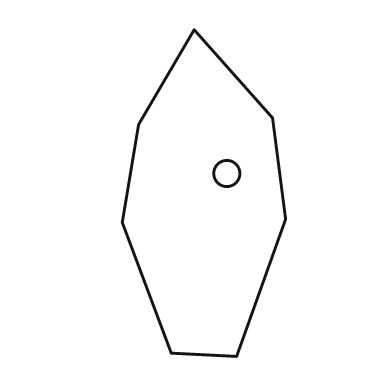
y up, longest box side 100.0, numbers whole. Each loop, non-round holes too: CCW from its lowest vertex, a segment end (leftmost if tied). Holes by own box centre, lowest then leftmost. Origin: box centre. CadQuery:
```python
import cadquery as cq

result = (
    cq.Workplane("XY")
    .moveTo(10.0, -50.0)
    .lineTo(25.0, -8.0)
    .lineTo(21.0, 23.0)
    .lineTo(-3.0, 50.0)
    .lineTo(-20.0, 21.0)
    .lineTo(-25.0, -9.0)
    .lineTo(-10.0, -49.0)
    .close()
    .moveTo(7.0, 6.0)
    .circle(4.0)
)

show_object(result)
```